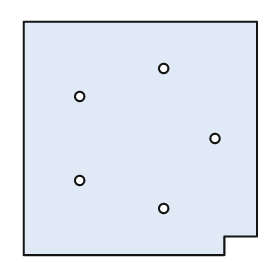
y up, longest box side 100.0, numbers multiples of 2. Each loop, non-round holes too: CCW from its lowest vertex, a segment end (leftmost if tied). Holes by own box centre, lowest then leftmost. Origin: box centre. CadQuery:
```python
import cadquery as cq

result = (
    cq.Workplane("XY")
    .moveTo(-50.0, -50.0)
    .lineTo(36.0, -50.0)
    .lineTo(36.0, -42.0)
    .lineTo(50.0, -42.0)
    .lineTo(50.0, 50.0)
    .lineTo(-50.0, 50.0)
    .close()
    .moveTo(10.0, -30.0)
    .circle(2.0)
    .moveTo(-26.0, -18.0)
    .circle(2.0)
    .moveTo(32.0, 0.0)
    .circle(2.0)
    .moveTo(-26.0, 18.0)
    .circle(2.0)
    .moveTo(10.0, 30.0)
    .circle(2.0)
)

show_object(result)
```